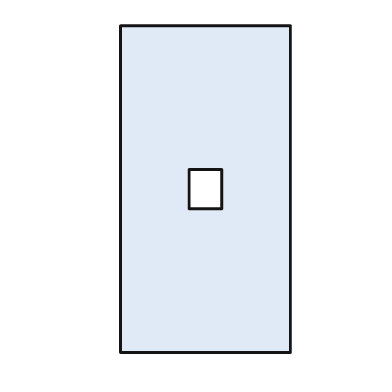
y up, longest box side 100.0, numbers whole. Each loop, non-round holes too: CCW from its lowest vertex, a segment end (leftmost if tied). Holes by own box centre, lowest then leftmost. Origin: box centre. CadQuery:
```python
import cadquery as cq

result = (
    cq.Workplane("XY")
    .moveTo(-26.0, -50.0)
    .lineTo(26.0, -50.0)
    .lineTo(26.0, 50.0)
    .lineTo(-26.0, 50.0)
    .close()
    .moveTo(-5.0, -6.0)
    .lineTo(5.0, -6.0)
    .lineTo(5.0, 6.0)
    .lineTo(-5.0, 6.0)
    .close()
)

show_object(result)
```